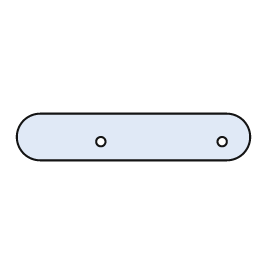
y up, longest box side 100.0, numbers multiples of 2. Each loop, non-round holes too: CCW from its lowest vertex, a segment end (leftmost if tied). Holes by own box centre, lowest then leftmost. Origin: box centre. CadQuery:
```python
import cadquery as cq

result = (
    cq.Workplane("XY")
    .moveTo(-40.0, -10.0)
    .lineTo(40.0, -10.0)
    .threePointArc((50.0, 0.0), (40.0, 10.0))
    .lineTo(-40.0, 10.0)
    .threePointArc((-50.0, 0.0), (-40.0, -10.0))
    .close()
    .moveTo(-14.0, -2.0)
    .circle(2.0)
    .moveTo(38.0, -2.0)
    .circle(2.0)
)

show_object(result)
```